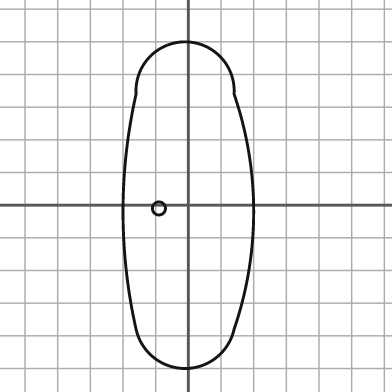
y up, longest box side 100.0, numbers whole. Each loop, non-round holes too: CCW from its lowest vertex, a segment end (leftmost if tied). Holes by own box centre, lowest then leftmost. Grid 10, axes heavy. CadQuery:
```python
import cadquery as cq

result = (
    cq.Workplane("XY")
    .moveTo(-16.0, -38.0)
    .threePointArc((-1.0, -50.0), (14.0, -38.0))
    .threePointArc((20.0, -2.0), (14.0, 34.0))
    .threePointArc((-1.0, 50.0), (-16.0, 34.0))
    .threePointArc((-20.0, -2.0), (-16.0, -38.0))
    .close()
    .moveTo(-9.0, -1.0)
    .circle(2.0)
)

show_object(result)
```